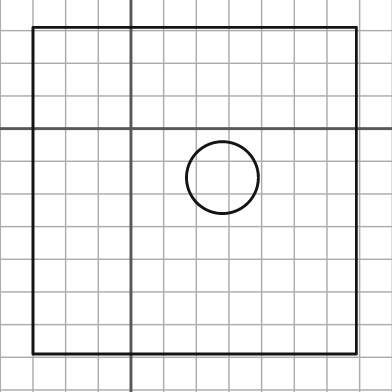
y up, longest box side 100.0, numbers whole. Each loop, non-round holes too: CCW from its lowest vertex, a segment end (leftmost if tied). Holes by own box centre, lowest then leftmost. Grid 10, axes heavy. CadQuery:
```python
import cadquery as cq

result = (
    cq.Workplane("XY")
    .moveTo(-30.0, -69.0)
    .lineTo(69.0, -69.0)
    .lineTo(69.0, 31.0)
    .lineTo(-30.0, 31.0)
    .close()
    .moveTo(28.0, -15.0)
    .circle(11.0)
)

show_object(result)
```